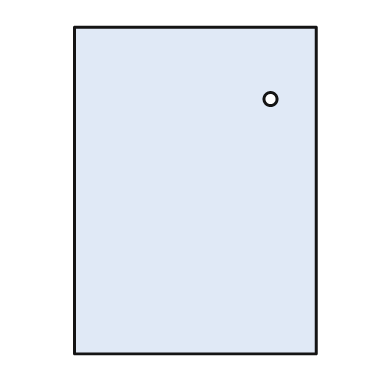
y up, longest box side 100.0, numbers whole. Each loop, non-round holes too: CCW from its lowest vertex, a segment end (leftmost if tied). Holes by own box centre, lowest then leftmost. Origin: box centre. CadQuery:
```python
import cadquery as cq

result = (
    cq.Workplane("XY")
    .moveTo(-37.0, -50.0)
    .lineTo(37.0, -50.0)
    .lineTo(37.0, 50.0)
    .lineTo(-37.0, 50.0)
    .close()
    .moveTo(23.0, 28.0)
    .circle(2.0)
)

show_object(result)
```